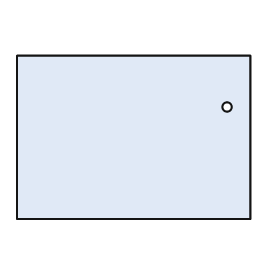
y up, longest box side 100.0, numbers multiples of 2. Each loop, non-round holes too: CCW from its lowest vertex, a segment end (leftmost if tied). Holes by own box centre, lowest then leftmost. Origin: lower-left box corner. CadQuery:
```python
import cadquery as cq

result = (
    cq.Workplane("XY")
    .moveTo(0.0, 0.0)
    .lineTo(100.0, 0.0)
    .lineTo(100.0, 70.0)
    .lineTo(0.0, 70.0)
    .close()
    .moveTo(90.0, 48.0)
    .circle(2.0)
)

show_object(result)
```